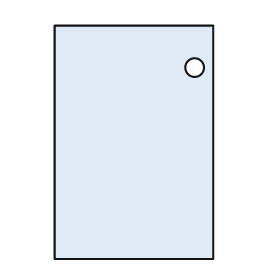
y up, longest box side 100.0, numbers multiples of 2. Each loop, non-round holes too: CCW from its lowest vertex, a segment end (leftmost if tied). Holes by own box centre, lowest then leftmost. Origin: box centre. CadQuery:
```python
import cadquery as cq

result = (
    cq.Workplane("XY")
    .moveTo(-34.0, -50.0)
    .lineTo(34.0, -50.0)
    .lineTo(34.0, 50.0)
    .lineTo(-34.0, 50.0)
    .close()
    .moveTo(26.0, 32.0)
    .circle(4.0)
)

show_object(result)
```